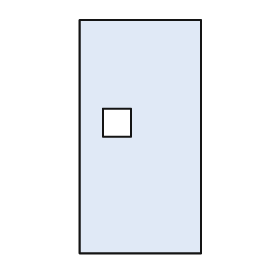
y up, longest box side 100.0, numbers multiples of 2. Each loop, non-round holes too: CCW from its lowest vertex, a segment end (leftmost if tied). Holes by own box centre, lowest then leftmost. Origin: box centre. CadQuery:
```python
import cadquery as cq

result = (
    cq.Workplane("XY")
    .moveTo(-26.0, -50.0)
    .lineTo(26.0, -50.0)
    .lineTo(26.0, 50.0)
    .lineTo(-26.0, 50.0)
    .close()
    .moveTo(-16.0, 0.0)
    .lineTo(-4.0, 0.0)
    .lineTo(-4.0, 12.0)
    .lineTo(-16.0, 12.0)
    .close()
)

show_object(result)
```